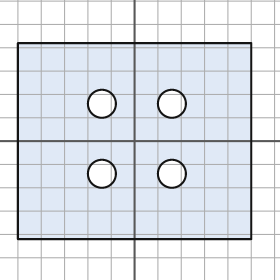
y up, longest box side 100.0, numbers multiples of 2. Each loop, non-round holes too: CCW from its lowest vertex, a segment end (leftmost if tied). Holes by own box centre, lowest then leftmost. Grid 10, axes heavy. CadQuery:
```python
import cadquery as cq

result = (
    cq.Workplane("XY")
    .moveTo(-50.0, -42.0)
    .lineTo(50.0, -42.0)
    .lineTo(50.0, 42.0)
    .lineTo(-50.0, 42.0)
    .close()
    .moveTo(-14.0, -14.0)
    .circle(6.0)
    .moveTo(16.0, -14.0)
    .circle(6.0)
    .moveTo(-14.0, 16.0)
    .circle(6.0)
    .moveTo(16.0, 16.0)
    .circle(6.0)
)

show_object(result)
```